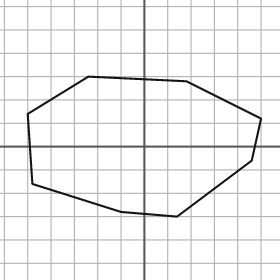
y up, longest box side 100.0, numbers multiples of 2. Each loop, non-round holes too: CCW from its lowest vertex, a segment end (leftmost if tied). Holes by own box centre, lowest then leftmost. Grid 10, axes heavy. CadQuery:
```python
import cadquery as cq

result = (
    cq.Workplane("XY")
    .moveTo(14.0, -30.0)
    .lineTo(46.0, -6.0)
    .lineTo(50.0, 12.0)
    .lineTo(18.0, 28.0)
    .lineTo(-24.0, 30.0)
    .lineTo(-50.0, 14.0)
    .lineTo(-48.0, -16.0)
    .lineTo(-10.0, -28.0)
    .close()
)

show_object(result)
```